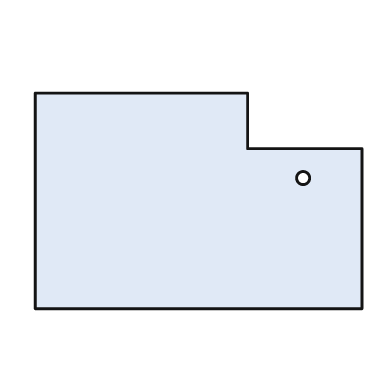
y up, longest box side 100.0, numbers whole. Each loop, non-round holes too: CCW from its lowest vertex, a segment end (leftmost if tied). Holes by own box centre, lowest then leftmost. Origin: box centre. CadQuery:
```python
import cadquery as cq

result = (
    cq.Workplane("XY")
    .moveTo(-50.0, -33.0)
    .lineTo(50.0, -33.0)
    .lineTo(50.0, 16.0)
    .lineTo(15.0, 16.0)
    .lineTo(15.0, 33.0)
    .lineTo(-50.0, 33.0)
    .close()
    .moveTo(32.0, 7.0)
    .circle(2.0)
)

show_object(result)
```